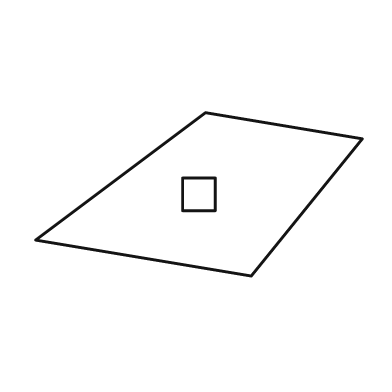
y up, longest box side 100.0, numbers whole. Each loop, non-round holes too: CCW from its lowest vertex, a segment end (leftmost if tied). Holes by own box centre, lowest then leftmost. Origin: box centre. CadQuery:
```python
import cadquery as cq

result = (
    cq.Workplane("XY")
    .moveTo(16.0, -25.0)
    .lineTo(50.0, 17.0)
    .lineTo(2.0, 25.0)
    .lineTo(-50.0, -14.0)
    .close()
    .moveTo(-5.0, -5.0)
    .lineTo(5.0, -5.0)
    .lineTo(5.0, 5.0)
    .lineTo(-5.0, 5.0)
    .close()
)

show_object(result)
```